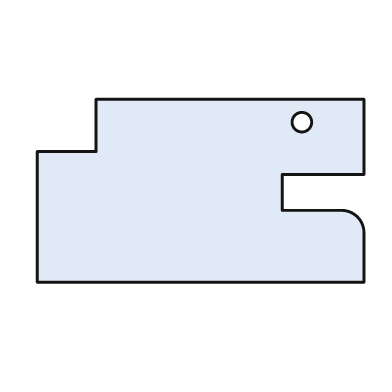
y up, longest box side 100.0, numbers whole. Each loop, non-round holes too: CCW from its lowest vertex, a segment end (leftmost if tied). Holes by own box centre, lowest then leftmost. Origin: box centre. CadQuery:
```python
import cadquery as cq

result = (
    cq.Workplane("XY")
    .moveTo(-50.0, -28.0)
    .lineTo(50.0, -28.0)
    .lineTo(50.0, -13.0)
    .threePointArc((48.0, -8.0), (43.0, -6.0))
    .lineTo(25.0, -6.0)
    .lineTo(25.0, 5.0)
    .lineTo(50.0, 5.0)
    .lineTo(50.0, 28.0)
    .lineTo(-32.0, 28.0)
    .lineTo(-32.0, 12.0)
    .lineTo(-50.0, 12.0)
    .close()
    .moveTo(31.0, 21.0)
    .circle(3.0)
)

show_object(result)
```